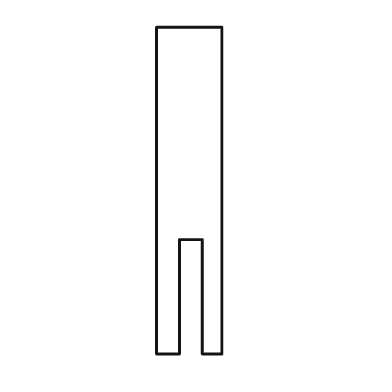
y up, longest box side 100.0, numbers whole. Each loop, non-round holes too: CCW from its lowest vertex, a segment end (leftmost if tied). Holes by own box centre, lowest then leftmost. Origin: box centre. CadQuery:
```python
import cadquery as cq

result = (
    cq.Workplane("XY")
    .moveTo(-10.0, -50.0)
    .lineTo(-3.0, -50.0)
    .lineTo(-3.0, -15.0)
    .lineTo(4.0, -15.0)
    .lineTo(4.0, -50.0)
    .lineTo(10.0, -50.0)
    .lineTo(10.0, 50.0)
    .lineTo(-10.0, 50.0)
    .close()
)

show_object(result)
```